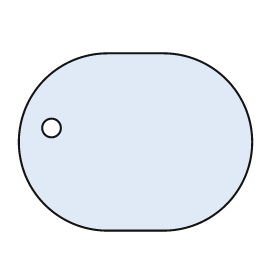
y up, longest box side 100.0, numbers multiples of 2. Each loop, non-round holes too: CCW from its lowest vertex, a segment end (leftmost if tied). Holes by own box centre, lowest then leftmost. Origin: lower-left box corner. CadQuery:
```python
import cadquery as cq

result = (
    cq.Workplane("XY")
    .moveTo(38.0, 0.0)
    .lineTo(62.0, 0.0)
    .threePointArc((100.0, 38.0), (62.0, 76.0))
    .lineTo(38.0, 76.0)
    .threePointArc((0.0, 38.0), (38.0, 0.0))
    .close()
    .moveTo(14.0, 44.0)
    .circle(4.0)
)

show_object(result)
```